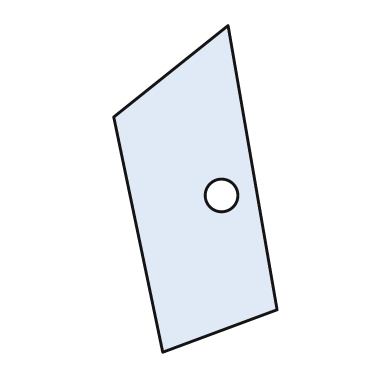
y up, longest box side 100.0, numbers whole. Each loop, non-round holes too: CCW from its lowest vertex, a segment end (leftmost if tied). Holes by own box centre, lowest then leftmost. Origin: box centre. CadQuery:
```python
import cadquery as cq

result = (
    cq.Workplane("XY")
    .moveTo(-10.0, -50.0)
    .lineTo(25.0, -37.0)
    .lineTo(10.0, 50.0)
    .lineTo(-25.0, 22.0)
    .close()
    .moveTo(8.0, -2.0)
    .circle(5.0)
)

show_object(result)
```